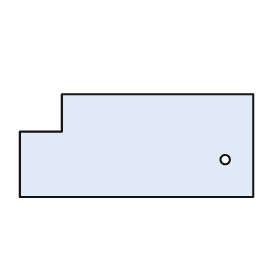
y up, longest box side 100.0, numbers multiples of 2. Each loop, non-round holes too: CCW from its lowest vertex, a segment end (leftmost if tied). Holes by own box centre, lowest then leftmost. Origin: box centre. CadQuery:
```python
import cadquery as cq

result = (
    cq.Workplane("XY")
    .moveTo(-50.0, -22.0)
    .lineTo(50.0, -22.0)
    .lineTo(50.0, 22.0)
    .lineTo(-32.0, 22.0)
    .lineTo(-32.0, 6.0)
    .lineTo(-50.0, 6.0)
    .close()
    .moveTo(38.0, -6.0)
    .circle(2.0)
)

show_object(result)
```